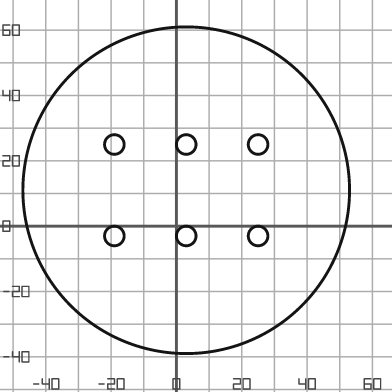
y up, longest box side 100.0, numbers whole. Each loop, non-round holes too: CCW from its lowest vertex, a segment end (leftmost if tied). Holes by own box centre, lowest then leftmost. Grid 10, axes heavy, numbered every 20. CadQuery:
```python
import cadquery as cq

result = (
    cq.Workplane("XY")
    .moveTo(3.0, 11.0)
    .circle(50.0)
    .moveTo(-19.0, -3.0)
    .circle(3.0)
    .moveTo(3.0, -3.0)
    .circle(3.0)
    .moveTo(25.0, -3.0)
    .circle(3.0)
    .moveTo(-19.0, 25.0)
    .circle(3.0)
    .moveTo(3.0, 25.0)
    .circle(3.0)
    .moveTo(25.0, 25.0)
    .circle(3.0)
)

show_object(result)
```